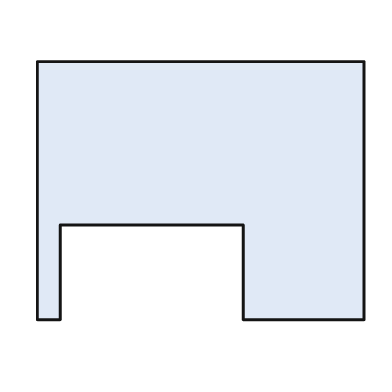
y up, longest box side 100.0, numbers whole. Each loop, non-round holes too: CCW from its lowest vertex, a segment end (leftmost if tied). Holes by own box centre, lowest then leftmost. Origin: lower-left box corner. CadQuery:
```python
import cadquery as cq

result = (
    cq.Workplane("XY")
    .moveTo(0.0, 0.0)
    .lineTo(7.0, 0.0)
    .lineTo(7.0, 29.0)
    .lineTo(63.0, 29.0)
    .lineTo(63.0, 0.0)
    .lineTo(100.0, 0.0)
    .lineTo(100.0, 79.0)
    .lineTo(0.0, 79.0)
    .close()
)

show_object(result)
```